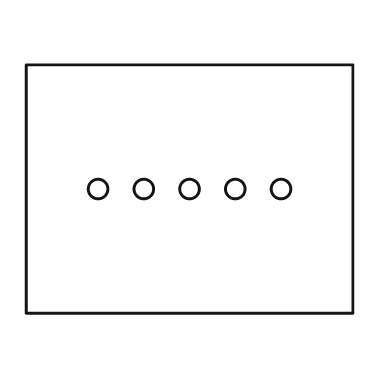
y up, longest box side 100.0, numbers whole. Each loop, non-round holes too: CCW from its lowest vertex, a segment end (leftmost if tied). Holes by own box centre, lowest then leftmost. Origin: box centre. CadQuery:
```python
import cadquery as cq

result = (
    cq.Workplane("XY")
    .moveTo(-50.0, -38.0)
    .lineTo(50.0, -38.0)
    .lineTo(50.0, 38.0)
    .lineTo(-50.0, 38.0)
    .close()
    .moveTo(-28.0, 0.0)
    .circle(3.0)
    .moveTo(-14.0, 0.0)
    .circle(3.0)
    .moveTo(0.0, 0.0)
    .circle(3.0)
    .moveTo(14.0, 0.0)
    .circle(3.0)
    .moveTo(28.0, 0.0)
    .circle(3.0)
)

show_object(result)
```